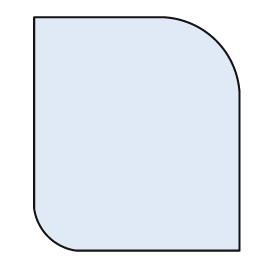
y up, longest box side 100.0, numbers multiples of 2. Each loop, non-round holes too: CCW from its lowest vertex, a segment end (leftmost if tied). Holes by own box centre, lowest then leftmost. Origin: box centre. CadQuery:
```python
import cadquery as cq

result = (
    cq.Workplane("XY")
    .moveTo(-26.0, -50.0)
    .lineTo(44.0, -50.0)
    .lineTo(44.0, 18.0)
    .threePointArc((34.0, 40.0), (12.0, 50.0))
    .lineTo(-44.0, 50.0)
    .lineTo(-44.0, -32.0)
    .threePointArc((-38.0, -44.0), (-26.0, -50.0))
    .close()
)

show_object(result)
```